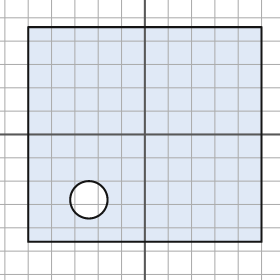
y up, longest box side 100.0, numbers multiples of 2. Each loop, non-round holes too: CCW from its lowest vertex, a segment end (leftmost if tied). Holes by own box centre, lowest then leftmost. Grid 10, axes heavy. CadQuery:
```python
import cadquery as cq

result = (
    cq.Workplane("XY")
    .moveTo(-50.0, -46.0)
    .lineTo(50.0, -46.0)
    .lineTo(50.0, 46.0)
    .lineTo(-50.0, 46.0)
    .close()
    .moveTo(-24.0, -28.0)
    .circle(8.0)
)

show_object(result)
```